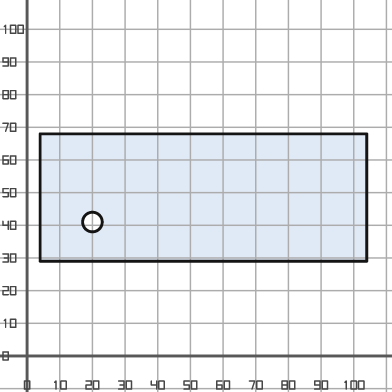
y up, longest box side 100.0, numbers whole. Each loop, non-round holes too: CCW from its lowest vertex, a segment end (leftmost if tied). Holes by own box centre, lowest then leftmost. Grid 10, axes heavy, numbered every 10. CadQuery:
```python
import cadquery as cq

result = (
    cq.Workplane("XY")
    .moveTo(4.0, 29.0)
    .lineTo(104.0, 29.0)
    .lineTo(104.0, 68.0)
    .lineTo(4.0, 68.0)
    .close()
    .moveTo(20.0, 41.0)
    .circle(3.0)
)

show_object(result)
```